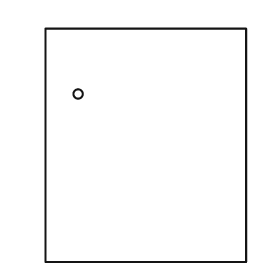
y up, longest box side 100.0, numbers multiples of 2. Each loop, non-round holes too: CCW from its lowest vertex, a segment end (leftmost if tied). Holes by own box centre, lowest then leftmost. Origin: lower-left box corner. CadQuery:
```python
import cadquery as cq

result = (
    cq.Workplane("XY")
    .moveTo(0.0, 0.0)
    .lineTo(86.0, 0.0)
    .lineTo(86.0, 100.0)
    .lineTo(0.0, 100.0)
    .close()
    .moveTo(14.0, 72.0)
    .circle(2.0)
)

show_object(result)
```